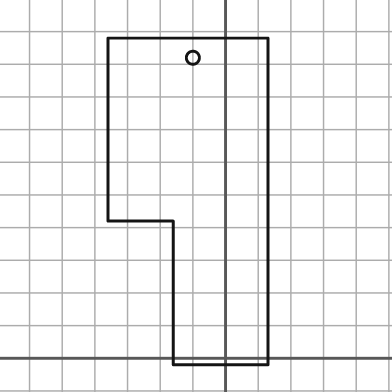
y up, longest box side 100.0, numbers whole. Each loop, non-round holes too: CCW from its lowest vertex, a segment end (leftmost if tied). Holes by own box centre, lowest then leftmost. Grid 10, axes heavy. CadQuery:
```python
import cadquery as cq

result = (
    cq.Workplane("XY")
    .moveTo(-16.0, -2.0)
    .lineTo(13.0, -2.0)
    .lineTo(13.0, 98.0)
    .lineTo(-36.0, 98.0)
    .lineTo(-36.0, 42.0)
    .lineTo(-16.0, 42.0)
    .close()
    .moveTo(-10.0, 92.0)
    .circle(2.0)
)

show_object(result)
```